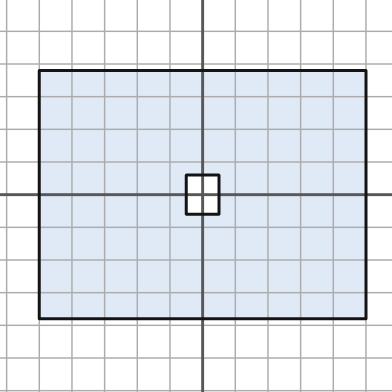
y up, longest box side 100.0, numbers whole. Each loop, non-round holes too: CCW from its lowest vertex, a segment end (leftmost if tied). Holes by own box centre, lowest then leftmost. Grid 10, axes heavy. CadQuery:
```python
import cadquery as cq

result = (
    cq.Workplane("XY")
    .moveTo(-50.0, -38.0)
    .lineTo(50.0, -38.0)
    .lineTo(50.0, 38.0)
    .lineTo(-50.0, 38.0)
    .close()
    .moveTo(-5.0, -6.0)
    .lineTo(5.0, -6.0)
    .lineTo(5.0, 6.0)
    .lineTo(-5.0, 6.0)
    .close()
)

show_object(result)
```